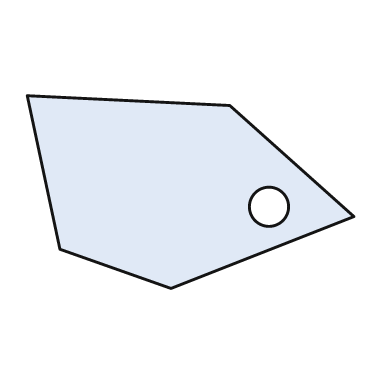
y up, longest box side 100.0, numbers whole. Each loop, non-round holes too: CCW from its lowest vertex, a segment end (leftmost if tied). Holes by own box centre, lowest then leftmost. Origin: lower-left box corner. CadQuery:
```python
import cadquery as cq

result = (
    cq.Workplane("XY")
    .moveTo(44.0, 0.0)
    .lineTo(100.0, 22.0)
    .lineTo(62.0, 56.0)
    .lineTo(0.0, 59.0)
    .lineTo(10.0, 12.0)
    .close()
    .moveTo(74.0, 25.0)
    .circle(6.0)
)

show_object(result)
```